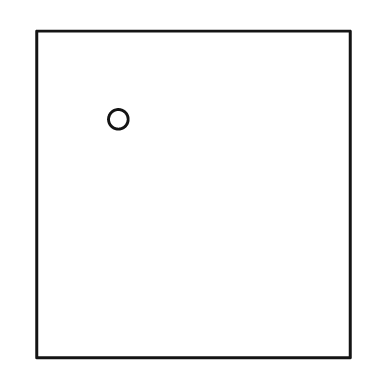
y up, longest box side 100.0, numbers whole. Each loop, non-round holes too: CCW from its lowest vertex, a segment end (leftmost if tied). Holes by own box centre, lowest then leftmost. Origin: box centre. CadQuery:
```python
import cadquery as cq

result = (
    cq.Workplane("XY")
    .moveTo(-48.0, -50.0)
    .lineTo(48.0, -50.0)
    .lineTo(48.0, 50.0)
    .lineTo(-48.0, 50.0)
    .close()
    .moveTo(-23.0, 23.0)
    .circle(3.0)
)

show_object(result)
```